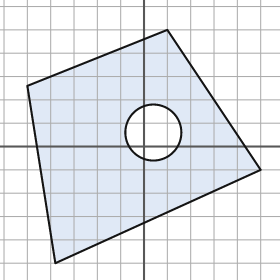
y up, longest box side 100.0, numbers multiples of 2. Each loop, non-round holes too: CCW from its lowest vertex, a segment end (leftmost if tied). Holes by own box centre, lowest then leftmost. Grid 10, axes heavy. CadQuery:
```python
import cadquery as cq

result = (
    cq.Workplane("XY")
    .moveTo(-38.0, -50.0)
    .lineTo(50.0, -10.0)
    .lineTo(10.0, 50.0)
    .lineTo(-50.0, 26.0)
    .close()
    .moveTo(4.0, 6.0)
    .circle(12.0)
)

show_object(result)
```